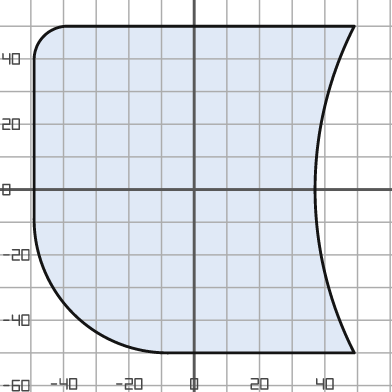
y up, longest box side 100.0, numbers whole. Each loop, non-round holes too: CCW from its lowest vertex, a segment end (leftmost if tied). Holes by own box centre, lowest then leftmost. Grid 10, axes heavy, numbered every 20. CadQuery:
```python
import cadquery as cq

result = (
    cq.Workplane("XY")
    .moveTo(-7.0, -50.0)
    .lineTo(49.0, -50.0)
    .threePointArc((37.0, 0.0), (49.0, 50.0))
    .lineTo(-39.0, 50.0)
    .threePointArc((-46.0, 47.0), (-49.0, 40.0))
    .lineTo(-49.0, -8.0)
    .threePointArc((-37.0, -38.0), (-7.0, -50.0))
    .close()
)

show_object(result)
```